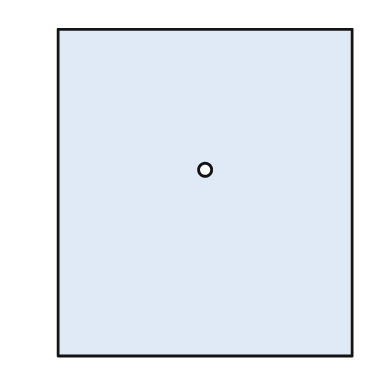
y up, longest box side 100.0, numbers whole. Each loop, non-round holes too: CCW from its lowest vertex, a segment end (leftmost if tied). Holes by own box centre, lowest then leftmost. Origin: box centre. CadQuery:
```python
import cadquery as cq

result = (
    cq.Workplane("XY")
    .moveTo(-45.0, -50.0)
    .lineTo(45.0, -50.0)
    .lineTo(45.0, 50.0)
    .lineTo(-45.0, 50.0)
    .close()
    .moveTo(0.0, 7.0)
    .circle(2.0)
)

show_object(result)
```